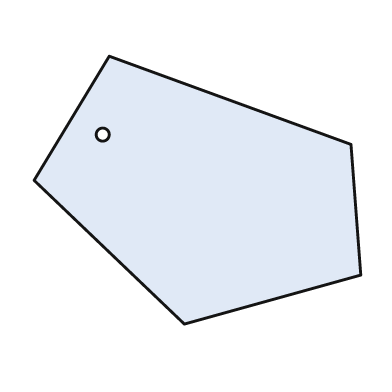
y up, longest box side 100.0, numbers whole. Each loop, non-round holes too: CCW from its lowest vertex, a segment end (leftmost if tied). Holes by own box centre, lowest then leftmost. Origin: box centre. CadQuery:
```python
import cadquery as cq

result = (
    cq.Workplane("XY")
    .moveTo(-4.0, -41.0)
    .lineTo(50.0, -26.0)
    .lineTo(47.0, 14.0)
    .lineTo(-27.0, 41.0)
    .lineTo(-50.0, 3.0)
    .close()
    .moveTo(-29.0, 17.0)
    .circle(2.0)
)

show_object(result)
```